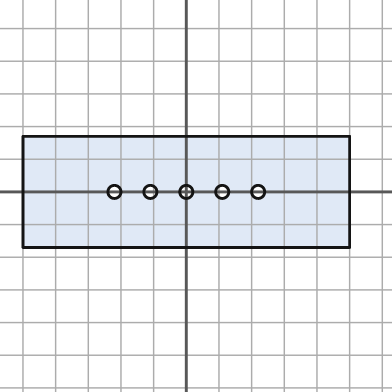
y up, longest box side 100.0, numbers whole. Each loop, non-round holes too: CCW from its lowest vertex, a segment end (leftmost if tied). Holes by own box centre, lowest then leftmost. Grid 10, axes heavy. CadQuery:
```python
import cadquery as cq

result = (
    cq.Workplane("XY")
    .moveTo(-50.0, -17.0)
    .lineTo(50.0, -17.0)
    .lineTo(50.0, 17.0)
    .lineTo(-50.0, 17.0)
    .close()
    .moveTo(-22.0, 0.0)
    .circle(2.0)
    .moveTo(-11.0, 0.0)
    .circle(2.0)
    .moveTo(0.0, 0.0)
    .circle(2.0)
    .moveTo(11.0, 0.0)
    .circle(2.0)
    .moveTo(22.0, 0.0)
    .circle(2.0)
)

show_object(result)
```